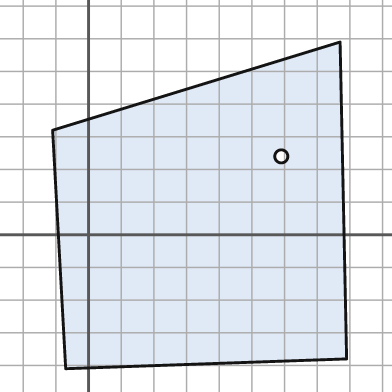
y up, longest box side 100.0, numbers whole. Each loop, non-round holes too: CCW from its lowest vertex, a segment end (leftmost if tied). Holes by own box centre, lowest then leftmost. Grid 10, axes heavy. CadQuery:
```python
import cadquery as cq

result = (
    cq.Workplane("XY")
    .moveTo(-7.0, -41.0)
    .lineTo(79.0, -38.0)
    .lineTo(77.0, 59.0)
    .lineTo(-11.0, 32.0)
    .close()
    .moveTo(59.0, 24.0)
    .circle(2.0)
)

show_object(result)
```